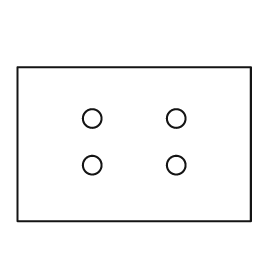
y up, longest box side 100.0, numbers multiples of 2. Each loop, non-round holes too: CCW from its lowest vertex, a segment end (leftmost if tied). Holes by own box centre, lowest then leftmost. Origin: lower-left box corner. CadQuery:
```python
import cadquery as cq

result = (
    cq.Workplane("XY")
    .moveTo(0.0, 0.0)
    .lineTo(100.0, 0.0)
    .lineTo(100.0, 66.0)
    .lineTo(0.0, 66.0)
    .close()
    .moveTo(32.0, 24.0)
    .circle(4.0)
    .moveTo(68.0, 24.0)
    .circle(4.0)
    .moveTo(32.0, 44.0)
    .circle(4.0)
    .moveTo(68.0, 44.0)
    .circle(4.0)
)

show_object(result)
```